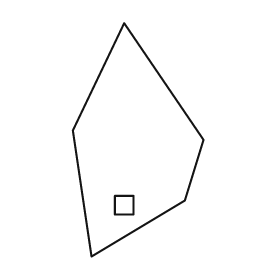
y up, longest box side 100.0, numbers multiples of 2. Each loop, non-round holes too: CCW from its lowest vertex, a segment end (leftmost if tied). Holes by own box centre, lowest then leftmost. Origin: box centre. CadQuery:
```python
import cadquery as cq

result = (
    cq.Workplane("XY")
    .moveTo(-20.0, -50.0)
    .lineTo(20.0, -26.0)
    .lineTo(28.0, 0.0)
    .lineTo(-6.0, 50.0)
    .lineTo(-28.0, 4.0)
    .close()
    .moveTo(-10.0, -32.0)
    .lineTo(-2.0, -32.0)
    .lineTo(-2.0, -24.0)
    .lineTo(-10.0, -24.0)
    .close()
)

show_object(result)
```